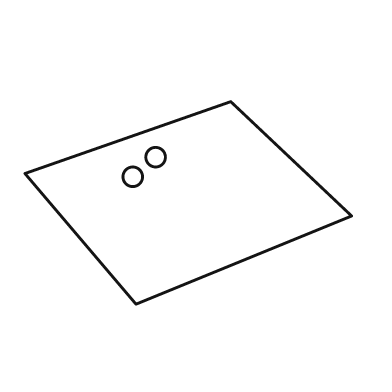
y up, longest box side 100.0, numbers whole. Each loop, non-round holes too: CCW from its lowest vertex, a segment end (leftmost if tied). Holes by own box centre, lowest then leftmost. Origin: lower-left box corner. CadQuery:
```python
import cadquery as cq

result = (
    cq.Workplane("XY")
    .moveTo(34.0, 0.0)
    .lineTo(100.0, 27.0)
    .lineTo(63.0, 62.0)
    .lineTo(0.0, 40.0)
    .close()
    .moveTo(33.0, 39.0)
    .circle(3.0)
    .moveTo(40.0, 45.0)
    .circle(3.0)
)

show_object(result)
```